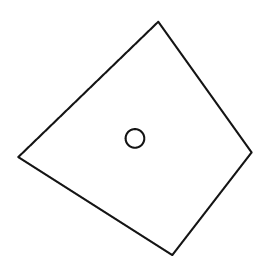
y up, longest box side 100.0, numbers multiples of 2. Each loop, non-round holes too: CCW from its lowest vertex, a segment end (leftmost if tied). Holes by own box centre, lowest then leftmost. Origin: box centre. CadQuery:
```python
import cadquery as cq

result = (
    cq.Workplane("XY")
    .moveTo(16.0, -50.0)
    .lineTo(50.0, -6.0)
    .lineTo(10.0, 50.0)
    .lineTo(-50.0, -8.0)
    .close()
    .moveTo(0.0, 0.0)
    .circle(4.0)
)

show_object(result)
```